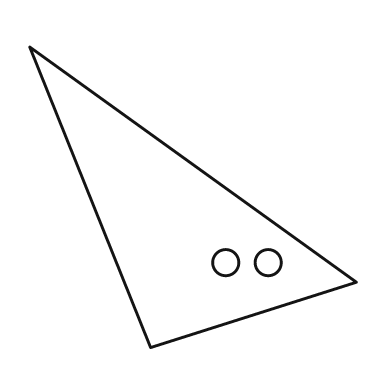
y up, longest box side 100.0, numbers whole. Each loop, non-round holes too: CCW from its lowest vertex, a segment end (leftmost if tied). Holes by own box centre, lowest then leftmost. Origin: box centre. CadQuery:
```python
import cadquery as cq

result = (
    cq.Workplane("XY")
    .moveTo(-13.0, -46.0)
    .lineTo(50.0, -26.0)
    .lineTo(-50.0, 46.0)
    .close()
    .moveTo(10.0, -20.0)
    .circle(4.0)
    .moveTo(23.0, -20.0)
    .circle(4.0)
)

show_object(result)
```